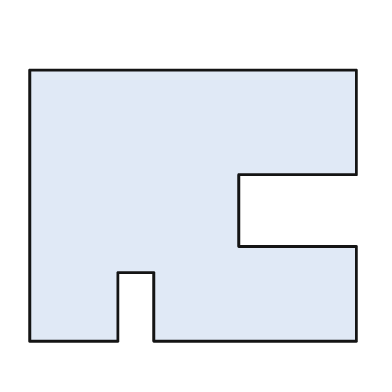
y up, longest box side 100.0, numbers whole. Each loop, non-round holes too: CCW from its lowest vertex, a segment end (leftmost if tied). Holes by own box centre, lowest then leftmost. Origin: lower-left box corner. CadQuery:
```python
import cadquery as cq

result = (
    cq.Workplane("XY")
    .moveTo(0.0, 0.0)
    .lineTo(27.0, 0.0)
    .lineTo(27.0, 21.0)
    .lineTo(38.0, 21.0)
    .lineTo(38.0, 0.0)
    .lineTo(100.0, 0.0)
    .lineTo(100.0, 29.0)
    .lineTo(64.0, 29.0)
    .lineTo(64.0, 51.0)
    .lineTo(100.0, 51.0)
    .lineTo(100.0, 83.0)
    .lineTo(0.0, 83.0)
    .close()
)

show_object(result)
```